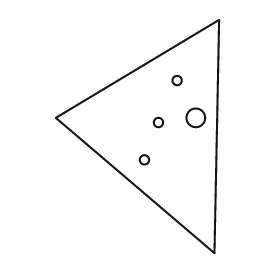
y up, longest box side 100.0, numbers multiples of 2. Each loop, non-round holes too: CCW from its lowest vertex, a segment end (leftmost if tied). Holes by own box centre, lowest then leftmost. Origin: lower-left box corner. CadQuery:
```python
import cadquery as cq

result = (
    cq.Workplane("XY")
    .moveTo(68.0, 0.0)
    .lineTo(70.0, 100.0)
    .lineTo(0.0, 58.0)
    .close()
    .moveTo(38.0, 40.0)
    .circle(2.0)
    .moveTo(44.0, 56.0)
    .circle(2.0)
    .moveTo(60.0, 58.0)
    .circle(4.0)
    .moveTo(52.0, 74.0)
    .circle(2.0)
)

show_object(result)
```